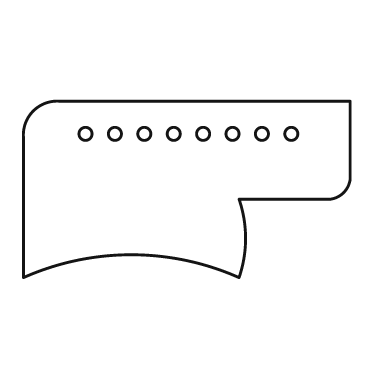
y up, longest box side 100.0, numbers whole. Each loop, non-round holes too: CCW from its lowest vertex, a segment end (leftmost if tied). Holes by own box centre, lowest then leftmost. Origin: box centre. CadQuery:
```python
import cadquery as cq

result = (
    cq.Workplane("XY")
    .moveTo(-50.0, -27.0)
    .threePointArc((-17.0, -20.0), (16.0, -27.0))
    .threePointArc((18.0, -15.0), (16.0, -3.0))
    .lineTo(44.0, -3.0)
    .threePointArc((48.0, -1.0), (50.0, 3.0))
    .lineTo(50.0, 27.0)
    .lineTo(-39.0, 27.0)
    .threePointArc((-47.0, 24.0), (-50.0, 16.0))
    .close()
    .moveTo(-31.0, 17.0)
    .circle(2.0)
    .moveTo(-22.0, 17.0)
    .circle(2.0)
    .moveTo(-13.0, 17.0)
    .circle(2.0)
    .moveTo(-4.0, 17.0)
    .circle(2.0)
    .moveTo(5.0, 17.0)
    .circle(2.0)
    .moveTo(14.0, 17.0)
    .circle(2.0)
    .moveTo(23.0, 17.0)
    .circle(2.0)
    .moveTo(32.0, 17.0)
    .circle(2.0)
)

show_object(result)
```